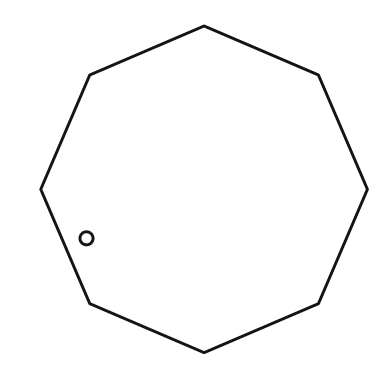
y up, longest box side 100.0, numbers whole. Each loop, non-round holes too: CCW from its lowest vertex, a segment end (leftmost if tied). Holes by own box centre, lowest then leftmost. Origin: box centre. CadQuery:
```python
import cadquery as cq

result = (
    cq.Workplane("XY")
    .moveTo(0.0, -50.0)
    .lineTo(35.0, -35.0)
    .lineTo(50.0, 0.0)
    .lineTo(35.0, 35.0)
    .lineTo(0.0, 50.0)
    .lineTo(-35.0, 35.0)
    .lineTo(-50.0, 0.0)
    .lineTo(-35.0, -35.0)
    .close()
    .moveTo(-36.0, -15.0)
    .circle(2.0)
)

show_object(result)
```